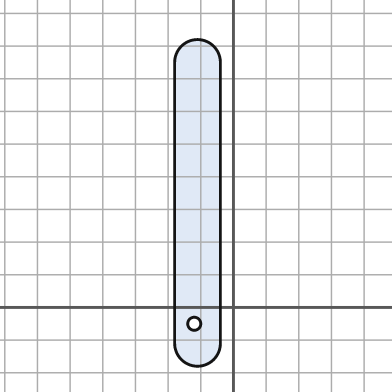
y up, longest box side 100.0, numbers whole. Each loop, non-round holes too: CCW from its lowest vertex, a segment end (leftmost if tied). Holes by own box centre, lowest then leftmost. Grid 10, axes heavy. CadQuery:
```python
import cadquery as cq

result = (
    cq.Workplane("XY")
    .moveTo(-18.0, -11.0)
    .threePointArc((-11.0, -18.0), (-4.0, -11.0))
    .lineTo(-4.0, 75.0)
    .threePointArc((-11.0, 82.0), (-18.0, 75.0))
    .close()
    .moveTo(-12.0, -5.0)
    .circle(2.0)
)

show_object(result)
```